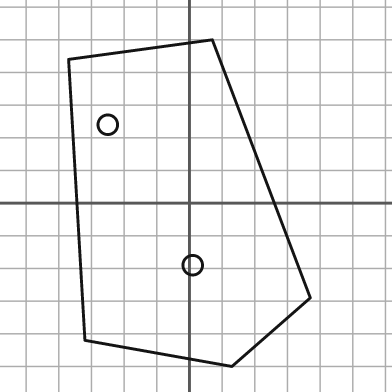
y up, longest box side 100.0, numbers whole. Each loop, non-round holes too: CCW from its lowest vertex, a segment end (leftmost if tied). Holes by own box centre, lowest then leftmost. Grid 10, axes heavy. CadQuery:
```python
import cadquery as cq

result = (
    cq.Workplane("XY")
    .moveTo(13.0, -50.0)
    .lineTo(37.0, -29.0)
    .lineTo(7.0, 50.0)
    .lineTo(-37.0, 44.0)
    .lineTo(-32.0, -42.0)
    .close()
    .moveTo(1.0, -19.0)
    .circle(3.0)
    .moveTo(-25.0, 24.0)
    .circle(3.0)
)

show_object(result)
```